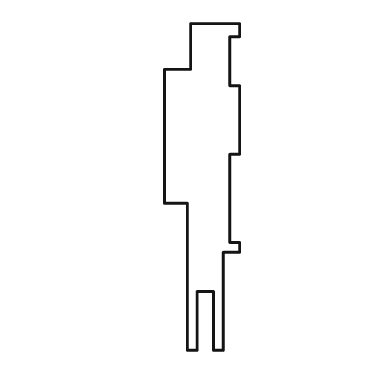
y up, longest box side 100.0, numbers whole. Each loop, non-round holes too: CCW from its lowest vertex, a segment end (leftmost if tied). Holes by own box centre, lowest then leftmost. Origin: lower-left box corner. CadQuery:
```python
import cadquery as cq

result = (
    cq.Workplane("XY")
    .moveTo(7.0, 0.0)
    .lineTo(10.0, 0.0)
    .lineTo(10.0, 18.0)
    .lineTo(15.0, 18.0)
    .lineTo(15.0, 0.0)
    .lineTo(18.0, 0.0)
    .lineTo(18.0, 30.0)
    .lineTo(23.0, 30.0)
    .lineTo(23.0, 33.0)
    .lineTo(20.0, 33.0)
    .lineTo(20.0, 60.0)
    .lineTo(23.0, 60.0)
    .lineTo(23.0, 81.0)
    .lineTo(20.0, 81.0)
    .lineTo(20.0, 96.0)
    .lineTo(23.0, 96.0)
    .lineTo(23.0, 100.0)
    .lineTo(8.0, 100.0)
    .lineTo(8.0, 86.0)
    .lineTo(0.0, 86.0)
    .lineTo(0.0, 45.0)
    .lineTo(7.0, 45.0)
    .close()
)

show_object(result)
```